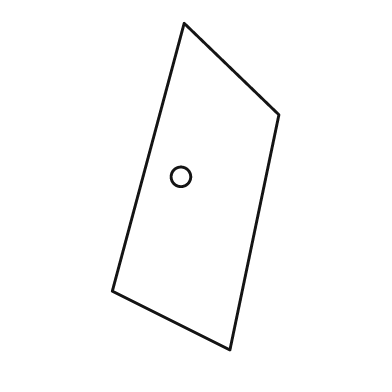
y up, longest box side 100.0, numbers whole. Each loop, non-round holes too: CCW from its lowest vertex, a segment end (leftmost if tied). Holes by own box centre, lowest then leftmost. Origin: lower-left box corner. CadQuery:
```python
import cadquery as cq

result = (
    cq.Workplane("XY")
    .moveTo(36.0, 0.0)
    .lineTo(51.0, 72.0)
    .lineTo(22.0, 100.0)
    .lineTo(0.0, 18.0)
    .close()
    .moveTo(21.0, 53.0)
    .circle(3.0)
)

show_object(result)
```